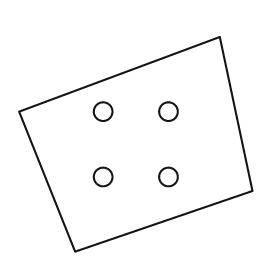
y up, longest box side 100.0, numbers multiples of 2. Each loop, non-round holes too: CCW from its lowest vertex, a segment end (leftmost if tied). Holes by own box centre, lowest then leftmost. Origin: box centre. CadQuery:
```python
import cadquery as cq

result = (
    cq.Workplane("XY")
    .moveTo(-26.0, -46.0)
    .lineTo(50.0, -20.0)
    .lineTo(36.0, 46.0)
    .lineTo(-50.0, 14.0)
    .close()
    .moveTo(-14.0, -14.0)
    .circle(4.0)
    .moveTo(14.0, -14.0)
    .circle(4.0)
    .moveTo(-14.0, 14.0)
    .circle(4.0)
    .moveTo(14.0, 14.0)
    .circle(4.0)
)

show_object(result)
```